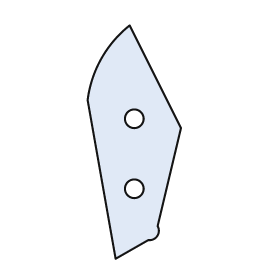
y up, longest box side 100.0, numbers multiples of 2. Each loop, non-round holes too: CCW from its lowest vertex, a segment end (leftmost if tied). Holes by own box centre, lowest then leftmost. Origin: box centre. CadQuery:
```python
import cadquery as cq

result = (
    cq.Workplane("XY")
    .moveTo(-8.0, -50.0)
    .lineTo(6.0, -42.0)
    .threePointArc((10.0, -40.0), (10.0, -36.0))
    .lineTo(20.0, 6.0)
    .lineTo(-2.0, 50.0)
    .threePointArc((-14.0, 36.0), (-20.0, 18.0))
    .close()
    .moveTo(0.0, -20.0)
    .circle(4.0)
    .moveTo(0.0, 10.0)
    .circle(4.0)
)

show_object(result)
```